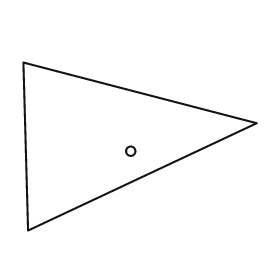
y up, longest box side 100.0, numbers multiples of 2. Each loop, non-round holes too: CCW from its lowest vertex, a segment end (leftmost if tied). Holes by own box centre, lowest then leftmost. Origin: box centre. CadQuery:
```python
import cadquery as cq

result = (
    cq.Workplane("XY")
    .moveTo(-48.0, -36.0)
    .lineTo(50.0, 10.0)
    .lineTo(-50.0, 36.0)
    .close()
    .moveTo(-4.0, -2.0)
    .circle(2.0)
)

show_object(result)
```